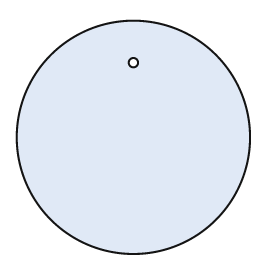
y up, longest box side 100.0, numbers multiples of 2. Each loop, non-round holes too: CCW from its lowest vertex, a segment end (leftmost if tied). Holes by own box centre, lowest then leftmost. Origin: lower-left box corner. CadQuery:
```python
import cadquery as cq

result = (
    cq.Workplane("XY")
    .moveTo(50.0, 50.0)
    .circle(50.0)
    .moveTo(50.0, 82.0)
    .circle(2.0)
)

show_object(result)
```